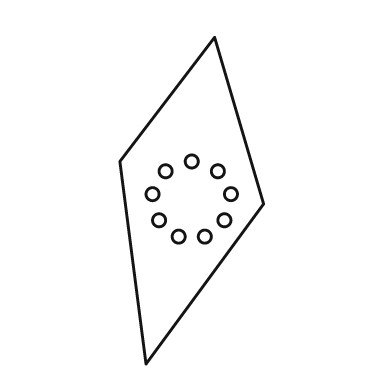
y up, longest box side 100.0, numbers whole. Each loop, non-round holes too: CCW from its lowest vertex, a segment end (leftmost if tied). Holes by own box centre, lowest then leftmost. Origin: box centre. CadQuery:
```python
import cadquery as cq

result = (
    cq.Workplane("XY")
    .moveTo(-14.0, -50.0)
    .lineTo(22.0, -1.0)
    .lineTo(7.0, 50.0)
    .lineTo(-22.0, 12.0)
    .close()
    .moveTo(-4.0, -11.0)
    .circle(2.0)
    .moveTo(4.0, -11.0)
    .circle(2.0)
    .moveTo(-10.0, -6.0)
    .circle(2.0)
    .moveTo(10.0, -6.0)
    .circle(2.0)
    .moveTo(-12.0, 2.0)
    .circle(2.0)
    .moveTo(12.0, 2.0)
    .circle(2.0)
    .moveTo(-8.0, 9.0)
    .circle(2.0)
    .moveTo(8.0, 9.0)
    .circle(2.0)
    .moveTo(0.0, 12.0)
    .circle(2.0)
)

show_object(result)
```